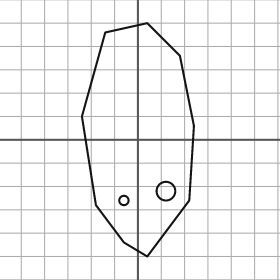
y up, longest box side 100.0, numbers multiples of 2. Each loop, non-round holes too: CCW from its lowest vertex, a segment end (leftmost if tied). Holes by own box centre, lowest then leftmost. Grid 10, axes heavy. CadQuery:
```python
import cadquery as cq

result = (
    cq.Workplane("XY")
    .moveTo(4.0, -50.0)
    .lineTo(22.0, -26.0)
    .lineTo(24.0, 6.0)
    .lineTo(18.0, 36.0)
    .lineTo(4.0, 50.0)
    .lineTo(-14.0, 46.0)
    .lineTo(-24.0, 10.0)
    .lineTo(-18.0, -28.0)
    .lineTo(-6.0, -44.0)
    .close()
    .moveTo(-6.0, -26.0)
    .circle(2.0)
    .moveTo(12.0, -22.0)
    .circle(4.0)
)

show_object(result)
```